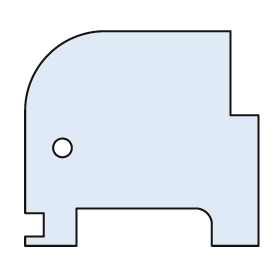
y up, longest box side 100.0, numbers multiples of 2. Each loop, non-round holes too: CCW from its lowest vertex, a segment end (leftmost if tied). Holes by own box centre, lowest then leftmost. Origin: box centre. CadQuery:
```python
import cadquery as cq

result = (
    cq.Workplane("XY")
    .moveTo(-50.0, -46.0)
    .lineTo(-28.0, -46.0)
    .lineTo(-28.0, -30.0)
    .lineTo(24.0, -30.0)
    .threePointArc((28.0, -32.0), (30.0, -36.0))
    .lineTo(30.0, -46.0)
    .lineTo(50.0, -46.0)
    .lineTo(50.0, 10.0)
    .lineTo(38.0, 10.0)
    .lineTo(38.0, 46.0)
    .lineTo(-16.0, 46.0)
    .threePointArc((-40.0, 36.0), (-50.0, 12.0))
    .lineTo(-50.0, -32.0)
    .lineTo(-42.0, -32.0)
    .lineTo(-42.0, -42.0)
    .lineTo(-50.0, -42.0)
    .close()
    .moveTo(-34.0, -4.0)
    .circle(4.0)
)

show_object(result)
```